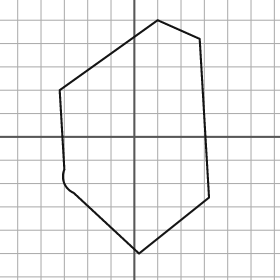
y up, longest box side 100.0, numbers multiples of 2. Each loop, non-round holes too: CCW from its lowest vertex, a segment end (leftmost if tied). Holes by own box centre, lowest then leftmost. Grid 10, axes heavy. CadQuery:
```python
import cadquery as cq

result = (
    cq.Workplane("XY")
    .moveTo(2.0, -50.0)
    .lineTo(32.0, -26.0)
    .lineTo(28.0, 42.0)
    .lineTo(10.0, 50.0)
    .lineTo(-32.0, 20.0)
    .lineTo(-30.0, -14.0)
    .threePointArc((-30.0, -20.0), (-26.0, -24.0))
    .close()
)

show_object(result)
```